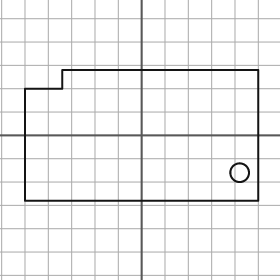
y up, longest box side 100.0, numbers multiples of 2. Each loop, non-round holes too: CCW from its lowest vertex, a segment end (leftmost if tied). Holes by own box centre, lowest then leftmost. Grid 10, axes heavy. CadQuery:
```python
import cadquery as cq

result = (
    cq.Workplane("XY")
    .moveTo(-50.0, -28.0)
    .lineTo(50.0, -28.0)
    .lineTo(50.0, 28.0)
    .lineTo(-34.0, 28.0)
    .lineTo(-34.0, 20.0)
    .lineTo(-50.0, 20.0)
    .close()
    .moveTo(42.0, -16.0)
    .circle(4.0)
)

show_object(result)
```